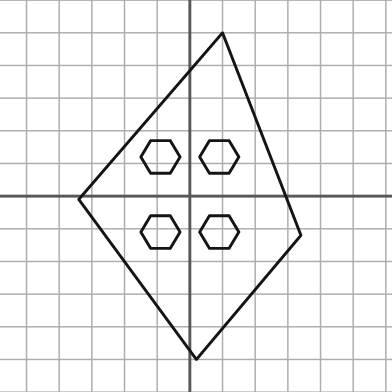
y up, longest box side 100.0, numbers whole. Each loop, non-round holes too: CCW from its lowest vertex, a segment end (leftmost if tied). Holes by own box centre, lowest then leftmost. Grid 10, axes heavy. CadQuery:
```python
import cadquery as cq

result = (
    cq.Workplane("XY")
    .moveTo(2.0, -50.0)
    .lineTo(34.0, -12.0)
    .lineTo(10.0, 50.0)
    .lineTo(-34.0, -1.0)
    .close()
    .moveTo(-12.0, -16.0)
    .lineTo(-6.0, -16.0)
    .lineTo(-3.0, -11.0)
    .lineTo(-6.0, -6.0)
    .lineTo(-12.0, -6.0)
    .lineTo(-15.0, -11.0)
    .close()
    .moveTo(6.0, -16.0)
    .lineTo(12.0, -16.0)
    .lineTo(15.0, -11.0)
    .lineTo(12.0, -6.0)
    .lineTo(6.0, -6.0)
    .lineTo(3.0, -11.0)
    .close()
    .moveTo(-12.0, 7.0)
    .lineTo(-6.0, 7.0)
    .lineTo(-3.0, 12.0)
    .lineTo(-6.0, 17.0)
    .lineTo(-12.0, 17.0)
    .lineTo(-15.0, 12.0)
    .close()
    .moveTo(6.0, 7.0)
    .lineTo(12.0, 7.0)
    .lineTo(15.0, 12.0)
    .lineTo(12.0, 17.0)
    .lineTo(6.0, 17.0)
    .lineTo(3.0, 12.0)
    .close()
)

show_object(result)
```